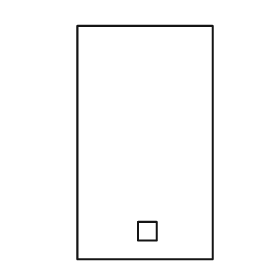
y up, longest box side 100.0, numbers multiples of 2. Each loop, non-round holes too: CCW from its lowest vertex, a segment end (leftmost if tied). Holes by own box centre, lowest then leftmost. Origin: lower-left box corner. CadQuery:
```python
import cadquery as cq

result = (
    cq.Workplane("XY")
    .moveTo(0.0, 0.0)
    .lineTo(58.0, 0.0)
    .lineTo(58.0, 100.0)
    .lineTo(0.0, 100.0)
    .close()
    .moveTo(26.0, 8.0)
    .lineTo(34.0, 8.0)
    .lineTo(34.0, 16.0)
    .lineTo(26.0, 16.0)
    .close()
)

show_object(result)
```